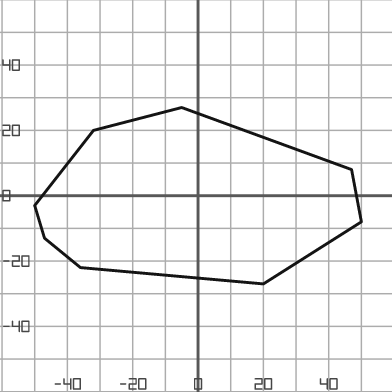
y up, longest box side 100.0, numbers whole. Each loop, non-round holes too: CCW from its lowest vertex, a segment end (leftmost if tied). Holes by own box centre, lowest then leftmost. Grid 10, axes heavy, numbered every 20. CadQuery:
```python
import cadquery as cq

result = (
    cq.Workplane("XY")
    .moveTo(20.0, -27.0)
    .lineTo(50.0, -8.0)
    .lineTo(47.0, 8.0)
    .lineTo(-5.0, 27.0)
    .lineTo(-32.0, 20.0)
    .lineTo(-50.0, -3.0)
    .lineTo(-47.0, -13.0)
    .lineTo(-36.0, -22.0)
    .close()
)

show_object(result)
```